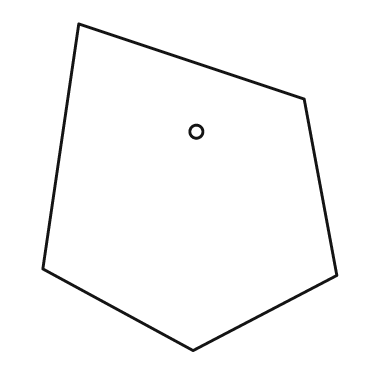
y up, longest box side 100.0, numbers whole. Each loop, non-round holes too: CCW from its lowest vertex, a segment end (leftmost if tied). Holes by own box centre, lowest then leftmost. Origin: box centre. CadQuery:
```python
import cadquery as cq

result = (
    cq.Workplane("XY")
    .moveTo(1.0, -50.0)
    .lineTo(45.0, -27.0)
    .lineTo(35.0, 27.0)
    .lineTo(-34.0, 50.0)
    .lineTo(-45.0, -25.0)
    .close()
    .moveTo(2.0, 17.0)
    .circle(2.0)
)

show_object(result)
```